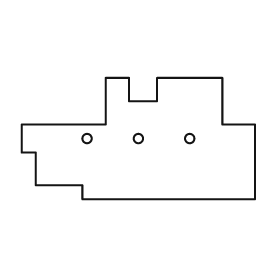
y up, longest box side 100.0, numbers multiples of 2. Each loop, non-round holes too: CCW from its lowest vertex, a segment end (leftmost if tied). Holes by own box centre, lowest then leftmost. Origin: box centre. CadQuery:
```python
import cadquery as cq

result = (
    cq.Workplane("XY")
    .moveTo(-24.0, -26.0)
    .lineTo(50.0, -26.0)
    .lineTo(50.0, 6.0)
    .lineTo(36.0, 6.0)
    .lineTo(36.0, 26.0)
    .lineTo(8.0, 26.0)
    .lineTo(8.0, 16.0)
    .lineTo(-4.0, 16.0)
    .lineTo(-4.0, 26.0)
    .lineTo(-14.0, 26.0)
    .lineTo(-14.0, 6.0)
    .lineTo(-50.0, 6.0)
    .lineTo(-50.0, -6.0)
    .lineTo(-44.0, -6.0)
    .lineTo(-44.0, -20.0)
    .lineTo(-24.0, -20.0)
    .close()
    .moveTo(-22.0, 0.0)
    .circle(2.0)
    .moveTo(0.0, 0.0)
    .circle(2.0)
    .moveTo(22.0, 0.0)
    .circle(2.0)
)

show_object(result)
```